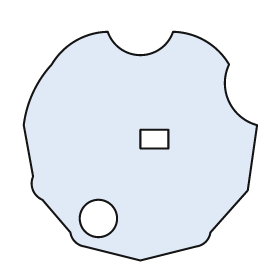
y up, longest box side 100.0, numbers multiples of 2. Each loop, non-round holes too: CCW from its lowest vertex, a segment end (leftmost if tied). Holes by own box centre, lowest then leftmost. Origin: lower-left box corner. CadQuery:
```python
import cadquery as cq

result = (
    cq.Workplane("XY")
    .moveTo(50.0, 0.0)
    .lineTo(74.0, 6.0)
    .threePointArc((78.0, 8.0), (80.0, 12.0))
    .lineTo(96.0, 30.0)
    .lineTo(100.0, 58.0)
    .threePointArc((88.0, 68.0), (88.0, 84.0))
    .threePointArc((78.0, 94.0), (64.0, 98.0))
    .threePointArc((50.0, 88.0), (36.0, 98.0))
    .threePointArc((22.0, 94.0), (12.0, 84.0))
    .threePointArc((4.0, 72.0), (0.0, 58.0))
    .lineTo(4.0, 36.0)
    .threePointArc((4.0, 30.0), (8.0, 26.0))
    .lineTo(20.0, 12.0)
    .threePointArc((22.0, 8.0), (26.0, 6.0))
    .close()
    .moveTo(32.0, 18.0)
    .circle(8.0)
    .moveTo(50.0, 48.0)
    .lineTo(62.0, 48.0)
    .lineTo(62.0, 56.0)
    .lineTo(50.0, 56.0)
    .close()
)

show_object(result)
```